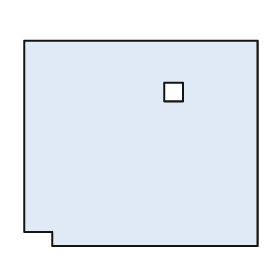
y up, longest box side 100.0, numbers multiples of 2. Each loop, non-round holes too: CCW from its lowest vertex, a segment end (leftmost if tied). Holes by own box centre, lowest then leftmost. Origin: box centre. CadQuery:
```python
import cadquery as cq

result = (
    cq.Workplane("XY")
    .moveTo(-38.0, -44.0)
    .lineTo(50.0, -44.0)
    .lineTo(50.0, 44.0)
    .lineTo(-50.0, 44.0)
    .lineTo(-50.0, -38.0)
    .lineTo(-38.0, -38.0)
    .close()
    .moveTo(10.0, 18.0)
    .lineTo(18.0, 18.0)
    .lineTo(18.0, 26.0)
    .lineTo(10.0, 26.0)
    .close()
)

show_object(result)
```